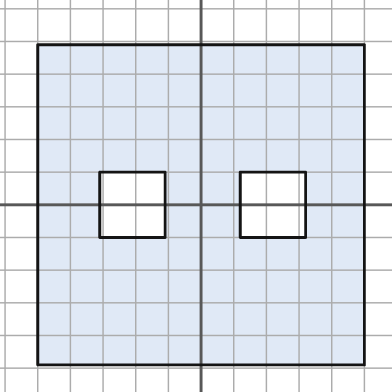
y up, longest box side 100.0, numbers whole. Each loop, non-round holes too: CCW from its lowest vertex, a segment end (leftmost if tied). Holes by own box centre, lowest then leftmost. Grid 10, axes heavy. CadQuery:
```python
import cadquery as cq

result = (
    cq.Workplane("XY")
    .moveTo(-50.0, -49.0)
    .lineTo(50.0, -49.0)
    .lineTo(50.0, 49.0)
    .lineTo(-50.0, 49.0)
    .close()
    .moveTo(-31.0, -10.0)
    .lineTo(-11.0, -10.0)
    .lineTo(-11.0, 10.0)
    .lineTo(-31.0, 10.0)
    .close()
    .moveTo(12.0, -10.0)
    .lineTo(32.0, -10.0)
    .lineTo(32.0, 10.0)
    .lineTo(12.0, 10.0)
    .close()
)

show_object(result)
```